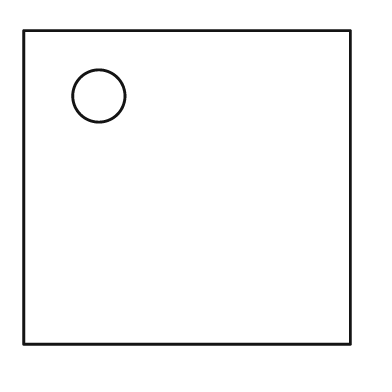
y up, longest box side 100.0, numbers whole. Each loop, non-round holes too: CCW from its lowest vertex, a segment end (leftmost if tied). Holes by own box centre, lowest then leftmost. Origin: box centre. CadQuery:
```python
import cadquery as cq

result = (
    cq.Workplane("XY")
    .moveTo(-50.0, -48.0)
    .lineTo(50.0, -48.0)
    .lineTo(50.0, 48.0)
    .lineTo(-50.0, 48.0)
    .close()
    .moveTo(-27.0, 28.0)
    .circle(8.0)
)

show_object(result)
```